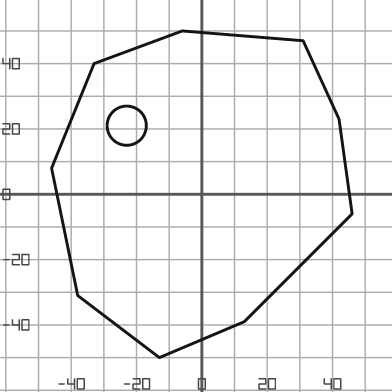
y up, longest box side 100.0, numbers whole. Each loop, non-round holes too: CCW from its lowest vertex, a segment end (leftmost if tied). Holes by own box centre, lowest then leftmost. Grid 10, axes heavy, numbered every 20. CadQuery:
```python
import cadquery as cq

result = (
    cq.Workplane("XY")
    .moveTo(-13.0, -50.0)
    .lineTo(13.0, -39.0)
    .lineTo(46.0, -6.0)
    .lineTo(42.0, 23.0)
    .lineTo(31.0, 47.0)
    .lineTo(-6.0, 50.0)
    .lineTo(-33.0, 40.0)
    .lineTo(-46.0, 8.0)
    .lineTo(-38.0, -31.0)
    .close()
    .moveTo(-23.0, 21.0)
    .circle(6.0)
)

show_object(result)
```